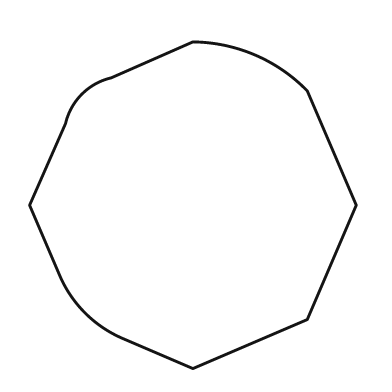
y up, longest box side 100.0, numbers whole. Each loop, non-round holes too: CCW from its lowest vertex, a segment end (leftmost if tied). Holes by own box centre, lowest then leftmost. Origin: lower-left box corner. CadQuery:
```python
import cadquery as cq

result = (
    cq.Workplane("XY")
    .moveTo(50.0, 0.0)
    .lineTo(85.0, 15.0)
    .lineTo(100.0, 50.0)
    .lineTo(85.0, 85.0)
    .threePointArc((69.0, 96.0), (50.0, 100.0))
    .lineTo(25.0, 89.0)
    .threePointArc((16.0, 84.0), (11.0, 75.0))
    .lineTo(0.0, 50.0)
    .lineTo(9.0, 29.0)
    .threePointArc((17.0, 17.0), (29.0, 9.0))
    .close()
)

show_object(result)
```